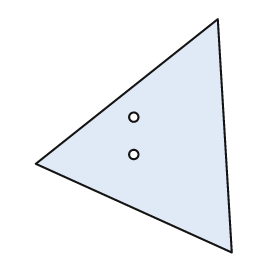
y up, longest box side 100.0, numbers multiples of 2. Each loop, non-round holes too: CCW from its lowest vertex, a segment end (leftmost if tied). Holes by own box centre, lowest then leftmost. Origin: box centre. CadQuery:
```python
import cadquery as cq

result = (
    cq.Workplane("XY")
    .moveTo(42.0, -50.0)
    .lineTo(36.0, 50.0)
    .lineTo(-42.0, -12.0)
    .close()
    .moveTo(0.0, -8.0)
    .circle(2.0)
    .moveTo(0.0, 8.0)
    .circle(2.0)
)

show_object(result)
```